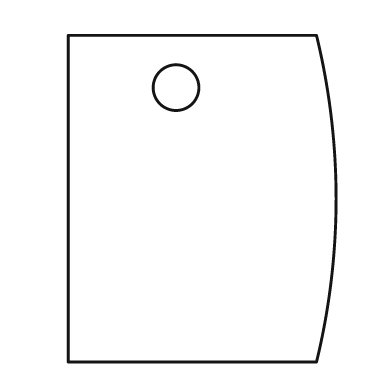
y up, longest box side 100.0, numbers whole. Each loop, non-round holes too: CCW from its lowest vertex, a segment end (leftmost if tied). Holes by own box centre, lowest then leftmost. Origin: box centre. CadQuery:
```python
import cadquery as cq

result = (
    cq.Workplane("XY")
    .moveTo(-41.0, -50.0)
    .lineTo(35.0, -50.0)
    .threePointArc((41.0, 0.0), (35.0, 50.0))
    .lineTo(-41.0, 50.0)
    .close()
    .moveTo(-8.0, 34.0)
    .circle(7.0)
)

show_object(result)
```